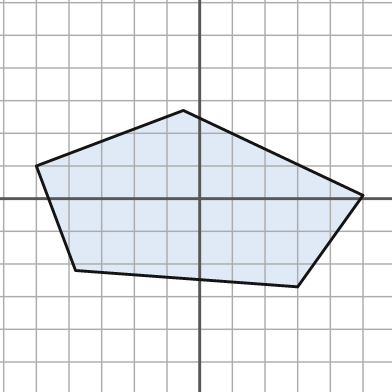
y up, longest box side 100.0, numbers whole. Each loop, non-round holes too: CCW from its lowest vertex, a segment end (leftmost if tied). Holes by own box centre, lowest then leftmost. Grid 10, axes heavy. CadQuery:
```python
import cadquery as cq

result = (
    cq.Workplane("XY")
    .moveTo(30.0, -27.0)
    .lineTo(50.0, 1.0)
    .lineTo(-5.0, 27.0)
    .lineTo(-50.0, 10.0)
    .lineTo(-38.0, -22.0)
    .close()
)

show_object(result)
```